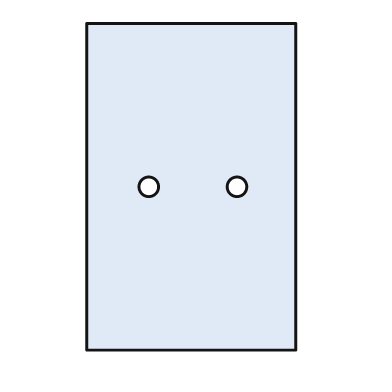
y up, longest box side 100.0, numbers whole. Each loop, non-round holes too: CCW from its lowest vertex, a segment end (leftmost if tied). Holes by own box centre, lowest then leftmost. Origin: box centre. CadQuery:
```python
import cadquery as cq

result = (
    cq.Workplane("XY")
    .moveTo(-32.0, -50.0)
    .lineTo(32.0, -50.0)
    .lineTo(32.0, 50.0)
    .lineTo(-32.0, 50.0)
    .close()
    .moveTo(-13.0, 0.0)
    .circle(3.0)
    .moveTo(14.0, 0.0)
    .circle(3.0)
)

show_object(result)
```